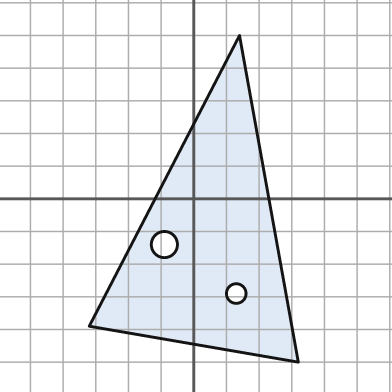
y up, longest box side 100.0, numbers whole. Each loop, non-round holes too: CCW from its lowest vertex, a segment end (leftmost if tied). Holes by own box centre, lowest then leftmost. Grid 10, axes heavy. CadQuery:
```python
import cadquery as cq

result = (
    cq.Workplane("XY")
    .moveTo(32.0, -50.0)
    .lineTo(14.0, 50.0)
    .lineTo(-32.0, -39.0)
    .close()
    .moveTo(13.0, -29.0)
    .circle(3.0)
    .moveTo(-9.0, -14.0)
    .circle(4.0)
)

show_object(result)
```